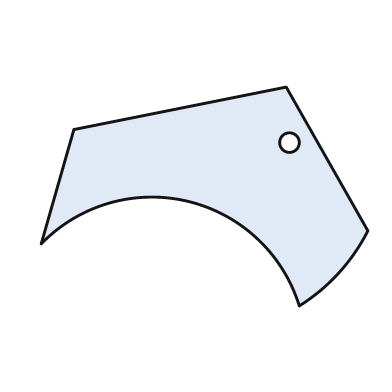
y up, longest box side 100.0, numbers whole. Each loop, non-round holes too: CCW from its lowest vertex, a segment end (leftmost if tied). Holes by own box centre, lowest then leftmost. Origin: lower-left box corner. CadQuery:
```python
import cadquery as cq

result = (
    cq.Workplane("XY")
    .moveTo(79.0, 0.0)
    .threePointArc((91.0, 10.0), (100.0, 23.0))
    .lineTo(75.0, 67.0)
    .lineTo(10.0, 54.0)
    .lineTo(0.0, 19.0)
    .threePointArc((45.0, 32.0), (79.0, 0.0))
    .close()
    .moveTo(76.0, 50.0)
    .circle(3.0)
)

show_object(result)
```